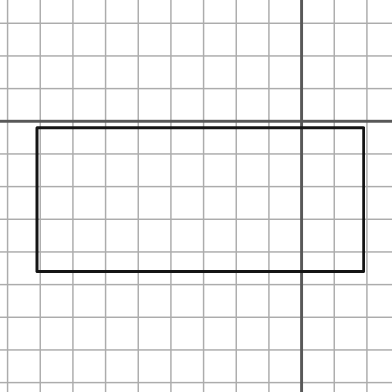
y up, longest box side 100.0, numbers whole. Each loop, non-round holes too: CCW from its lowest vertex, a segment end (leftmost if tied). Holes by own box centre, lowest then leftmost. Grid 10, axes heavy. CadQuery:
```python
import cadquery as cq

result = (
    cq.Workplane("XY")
    .moveTo(-81.0, -46.0)
    .lineTo(19.0, -46.0)
    .lineTo(19.0, -2.0)
    .lineTo(-81.0, -2.0)
    .close()
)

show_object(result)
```